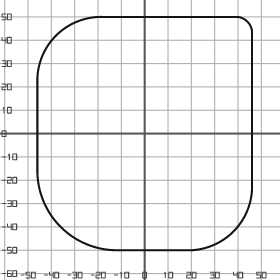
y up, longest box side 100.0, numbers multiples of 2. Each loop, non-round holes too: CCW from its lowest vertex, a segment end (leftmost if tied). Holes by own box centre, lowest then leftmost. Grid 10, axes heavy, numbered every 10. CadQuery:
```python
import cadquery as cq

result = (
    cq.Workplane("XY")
    .moveTo(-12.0, -50.0)
    .lineTo(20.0, -50.0)
    .threePointArc((38.0, -42.0), (46.0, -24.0))
    .lineTo(46.0, 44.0)
    .threePointArc((44.0, 48.0), (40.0, 50.0))
    .lineTo(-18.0, 50.0)
    .threePointArc((-38.0, 42.0), (-46.0, 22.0))
    .lineTo(-46.0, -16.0)
    .threePointArc((-36.0, -40.0), (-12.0, -50.0))
    .close()
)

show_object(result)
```